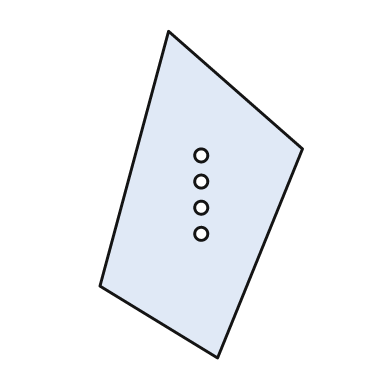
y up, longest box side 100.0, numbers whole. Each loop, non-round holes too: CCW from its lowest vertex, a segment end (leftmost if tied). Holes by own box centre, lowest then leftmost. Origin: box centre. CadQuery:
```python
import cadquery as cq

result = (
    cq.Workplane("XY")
    .moveTo(5.0, -50.0)
    .lineTo(31.0, 14.0)
    .lineTo(-10.0, 50.0)
    .lineTo(-31.0, -28.0)
    .close()
    .moveTo(0.0, -12.0)
    .circle(2.0)
    .moveTo(0.0, -4.0)
    .circle(2.0)
    .moveTo(0.0, 4.0)
    .circle(2.0)
    .moveTo(0.0, 12.0)
    .circle(2.0)
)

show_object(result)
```